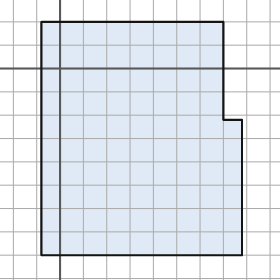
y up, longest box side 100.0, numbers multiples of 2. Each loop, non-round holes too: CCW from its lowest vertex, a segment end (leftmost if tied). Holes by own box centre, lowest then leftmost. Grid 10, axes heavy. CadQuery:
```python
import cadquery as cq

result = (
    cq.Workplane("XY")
    .moveTo(-8.0, -80.0)
    .lineTo(78.0, -80.0)
    .lineTo(78.0, -22.0)
    .lineTo(70.0, -22.0)
    .lineTo(70.0, 20.0)
    .lineTo(-8.0, 20.0)
    .close()
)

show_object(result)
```